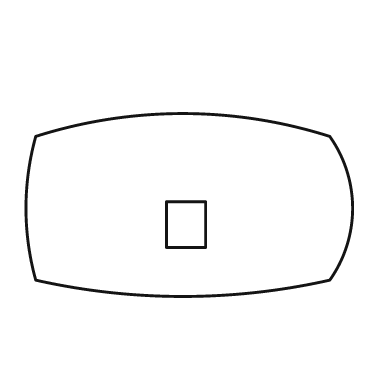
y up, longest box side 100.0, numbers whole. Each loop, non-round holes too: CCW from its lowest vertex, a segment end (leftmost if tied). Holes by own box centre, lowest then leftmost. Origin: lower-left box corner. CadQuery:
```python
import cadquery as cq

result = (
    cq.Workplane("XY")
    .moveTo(3.0, 5.0)
    .threePointArc((48.0, 0.0), (93.0, 5.0))
    .threePointArc((100.0, 27.0), (93.0, 49.0))
    .threePointArc((48.0, 56.0), (3.0, 49.0))
    .threePointArc((0.0, 27.0), (3.0, 5.0))
    .close()
    .moveTo(43.0, 15.0)
    .lineTo(55.0, 15.0)
    .lineTo(55.0, 29.0)
    .lineTo(43.0, 29.0)
    .close()
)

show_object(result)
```